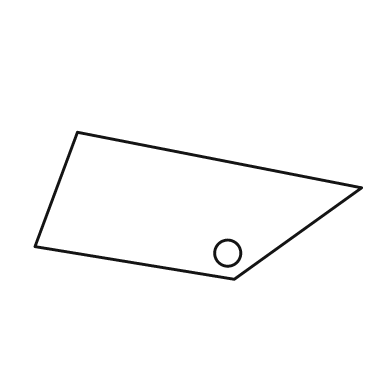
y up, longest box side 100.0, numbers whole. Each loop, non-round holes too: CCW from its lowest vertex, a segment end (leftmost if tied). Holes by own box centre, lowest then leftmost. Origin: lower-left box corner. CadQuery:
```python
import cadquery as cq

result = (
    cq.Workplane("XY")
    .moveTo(61.0, 0.0)
    .lineTo(100.0, 28.0)
    .lineTo(13.0, 45.0)
    .lineTo(0.0, 10.0)
    .close()
    .moveTo(59.0, 8.0)
    .circle(4.0)
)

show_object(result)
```